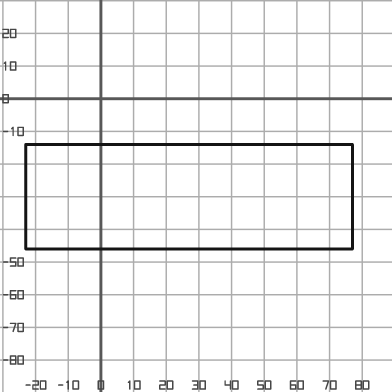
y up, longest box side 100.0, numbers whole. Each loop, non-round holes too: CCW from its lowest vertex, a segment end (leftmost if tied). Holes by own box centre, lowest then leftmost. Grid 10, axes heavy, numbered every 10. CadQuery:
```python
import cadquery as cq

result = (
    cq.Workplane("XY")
    .moveTo(-23.0, -46.0)
    .lineTo(77.0, -46.0)
    .lineTo(77.0, -14.0)
    .lineTo(-23.0, -14.0)
    .close()
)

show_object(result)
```